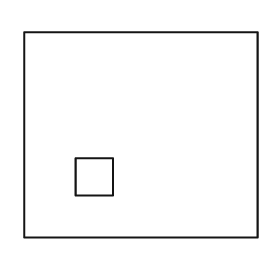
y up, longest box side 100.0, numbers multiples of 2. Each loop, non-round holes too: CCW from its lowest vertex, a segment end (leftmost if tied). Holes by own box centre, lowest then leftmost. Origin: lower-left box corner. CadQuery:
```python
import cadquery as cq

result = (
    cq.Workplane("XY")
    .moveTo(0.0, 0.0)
    .lineTo(100.0, 0.0)
    .lineTo(100.0, 88.0)
    .lineTo(0.0, 88.0)
    .close()
    .moveTo(22.0, 18.0)
    .lineTo(38.0, 18.0)
    .lineTo(38.0, 34.0)
    .lineTo(22.0, 34.0)
    .close()
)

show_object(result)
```